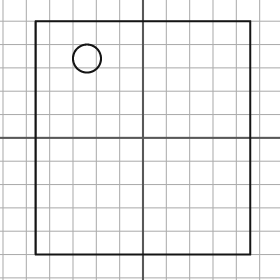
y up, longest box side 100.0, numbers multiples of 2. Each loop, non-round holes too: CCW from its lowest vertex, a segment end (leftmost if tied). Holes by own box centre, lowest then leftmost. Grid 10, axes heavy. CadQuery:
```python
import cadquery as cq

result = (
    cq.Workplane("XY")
    .moveTo(-46.0, -50.0)
    .lineTo(46.0, -50.0)
    .lineTo(46.0, 50.0)
    .lineTo(-46.0, 50.0)
    .close()
    .moveTo(-24.0, 34.0)
    .circle(6.0)
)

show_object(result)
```